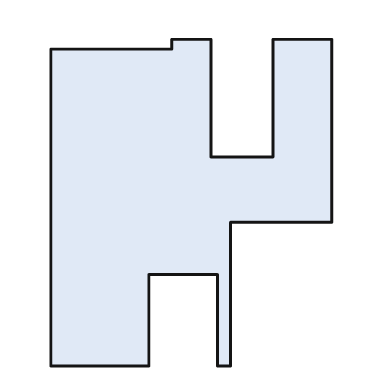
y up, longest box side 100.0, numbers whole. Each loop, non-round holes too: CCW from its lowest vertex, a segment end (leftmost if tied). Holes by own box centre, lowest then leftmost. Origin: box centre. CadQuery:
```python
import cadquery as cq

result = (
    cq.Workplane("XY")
    .moveTo(-43.0, -50.0)
    .lineTo(-13.0, -50.0)
    .lineTo(-13.0, -22.0)
    .lineTo(8.0, -22.0)
    .lineTo(8.0, -50.0)
    .lineTo(12.0, -50.0)
    .lineTo(12.0, -6.0)
    .lineTo(43.0, -6.0)
    .lineTo(43.0, 50.0)
    .lineTo(25.0, 50.0)
    .lineTo(25.0, 14.0)
    .lineTo(6.0, 14.0)
    .lineTo(6.0, 50.0)
    .lineTo(-6.0, 50.0)
    .lineTo(-6.0, 47.0)
    .lineTo(-43.0, 47.0)
    .close()
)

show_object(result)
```